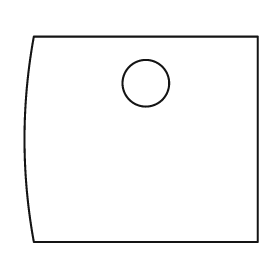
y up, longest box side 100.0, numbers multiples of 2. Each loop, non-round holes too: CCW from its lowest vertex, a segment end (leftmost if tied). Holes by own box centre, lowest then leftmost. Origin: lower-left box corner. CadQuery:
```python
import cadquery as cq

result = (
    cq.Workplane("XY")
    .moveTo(4.0, 0.0)
    .lineTo(100.0, 0.0)
    .lineTo(100.0, 88.0)
    .lineTo(4.0, 88.0)
    .threePointArc((0.0, 44.0), (4.0, 0.0))
    .close()
    .moveTo(52.0, 68.0)
    .circle(10.0)
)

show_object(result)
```